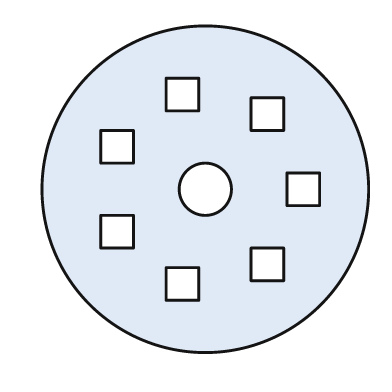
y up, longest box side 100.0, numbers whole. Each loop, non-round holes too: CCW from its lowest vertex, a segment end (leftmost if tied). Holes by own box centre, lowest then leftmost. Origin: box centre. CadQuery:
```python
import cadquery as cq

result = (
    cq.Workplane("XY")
    .moveTo(0.0, 0.0)
    .circle(50.0)
    .moveTo(-12.0, -34.0)
    .lineTo(-2.0, -34.0)
    .lineTo(-2.0, -24.0)
    .lineTo(-12.0, -24.0)
    .close()
    .moveTo(14.0, -28.0)
    .lineTo(24.0, -28.0)
    .lineTo(24.0, -18.0)
    .lineTo(14.0, -18.0)
    .close()
    .moveTo(-32.0, -18.0)
    .lineTo(-22.0, -18.0)
    .lineTo(-22.0, -8.0)
    .lineTo(-32.0, -8.0)
    .close()
    .moveTo(0.0, 0.0)
    .circle(8.0)
    .moveTo(25.0, -5.0)
    .lineTo(35.0, -5.0)
    .lineTo(35.0, 5.0)
    .lineTo(25.0, 5.0)
    .close()
    .moveTo(-32.0, 8.0)
    .lineTo(-22.0, 8.0)
    .lineTo(-22.0, 18.0)
    .lineTo(-32.0, 18.0)
    .close()
    .moveTo(14.0, 18.0)
    .lineTo(24.0, 18.0)
    .lineTo(24.0, 28.0)
    .lineTo(14.0, 28.0)
    .close()
    .moveTo(-12.0, 24.0)
    .lineTo(-2.0, 24.0)
    .lineTo(-2.0, 34.0)
    .lineTo(-12.0, 34.0)
    .close()
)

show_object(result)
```